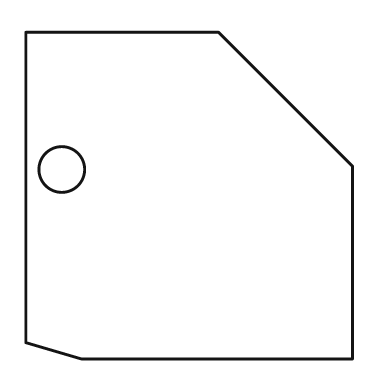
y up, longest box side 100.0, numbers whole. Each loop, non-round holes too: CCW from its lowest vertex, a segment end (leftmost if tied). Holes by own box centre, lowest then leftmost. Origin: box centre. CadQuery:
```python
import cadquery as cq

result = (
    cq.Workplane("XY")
    .moveTo(-33.0, -50.0)
    .lineTo(50.0, -50.0)
    .lineTo(50.0, 9.0)
    .lineTo(9.0, 50.0)
    .lineTo(-50.0, 50.0)
    .lineTo(-50.0, -45.0)
    .close()
    .moveTo(-39.0, 8.0)
    .circle(7.0)
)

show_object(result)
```